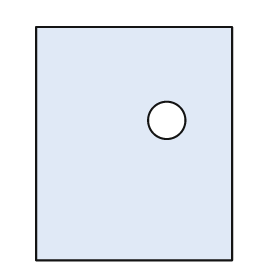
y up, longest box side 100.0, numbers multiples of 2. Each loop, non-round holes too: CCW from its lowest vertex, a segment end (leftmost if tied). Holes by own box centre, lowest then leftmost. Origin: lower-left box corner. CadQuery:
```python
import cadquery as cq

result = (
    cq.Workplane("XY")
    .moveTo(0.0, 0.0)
    .lineTo(84.0, 0.0)
    .lineTo(84.0, 100.0)
    .lineTo(0.0, 100.0)
    .close()
    .moveTo(56.0, 60.0)
    .circle(8.0)
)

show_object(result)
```